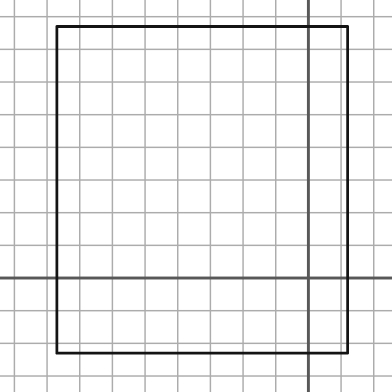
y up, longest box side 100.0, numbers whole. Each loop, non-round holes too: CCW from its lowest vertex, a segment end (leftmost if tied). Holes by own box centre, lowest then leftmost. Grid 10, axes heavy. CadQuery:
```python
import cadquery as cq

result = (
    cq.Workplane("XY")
    .moveTo(-77.0, -23.0)
    .lineTo(12.0, -23.0)
    .lineTo(12.0, 77.0)
    .lineTo(-77.0, 77.0)
    .close()
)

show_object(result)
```